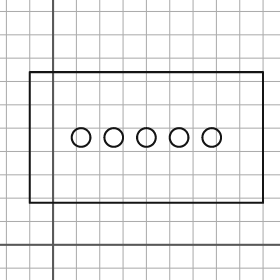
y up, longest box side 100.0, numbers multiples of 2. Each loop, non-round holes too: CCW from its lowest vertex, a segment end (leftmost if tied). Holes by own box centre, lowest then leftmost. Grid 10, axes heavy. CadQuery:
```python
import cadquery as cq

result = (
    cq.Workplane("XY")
    .moveTo(-10.0, 18.0)
    .lineTo(90.0, 18.0)
    .lineTo(90.0, 74.0)
    .lineTo(-10.0, 74.0)
    .close()
    .moveTo(12.0, 46.0)
    .circle(4.0)
    .moveTo(26.0, 46.0)
    .circle(4.0)
    .moveTo(40.0, 46.0)
    .circle(4.0)
    .moveTo(54.0, 46.0)
    .circle(4.0)
    .moveTo(68.0, 46.0)
    .circle(4.0)
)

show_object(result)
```